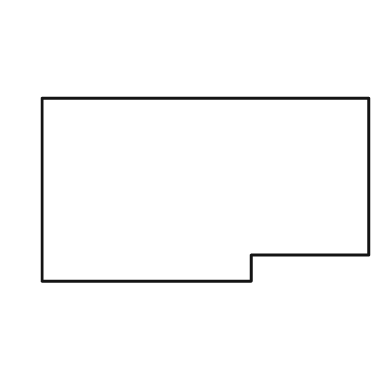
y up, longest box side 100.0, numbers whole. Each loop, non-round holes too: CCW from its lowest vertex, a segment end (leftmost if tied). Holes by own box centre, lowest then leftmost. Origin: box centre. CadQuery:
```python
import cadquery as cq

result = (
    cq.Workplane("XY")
    .moveTo(-50.0, -28.0)
    .lineTo(14.0, -28.0)
    .lineTo(14.0, -20.0)
    .lineTo(50.0, -20.0)
    .lineTo(50.0, 28.0)
    .lineTo(-50.0, 28.0)
    .close()
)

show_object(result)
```